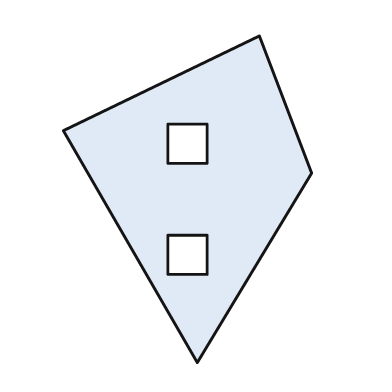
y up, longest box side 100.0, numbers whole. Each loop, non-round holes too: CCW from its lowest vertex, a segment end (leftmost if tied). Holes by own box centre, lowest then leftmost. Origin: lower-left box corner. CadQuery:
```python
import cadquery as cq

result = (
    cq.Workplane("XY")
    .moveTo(41.0, 0.0)
    .lineTo(76.0, 58.0)
    .lineTo(60.0, 100.0)
    .lineTo(0.0, 71.0)
    .close()
    .moveTo(32.0, 27.0)
    .lineTo(44.0, 27.0)
    .lineTo(44.0, 39.0)
    .lineTo(32.0, 39.0)
    .close()
    .moveTo(32.0, 61.0)
    .lineTo(44.0, 61.0)
    .lineTo(44.0, 73.0)
    .lineTo(32.0, 73.0)
    .close()
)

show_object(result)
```